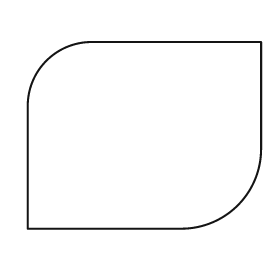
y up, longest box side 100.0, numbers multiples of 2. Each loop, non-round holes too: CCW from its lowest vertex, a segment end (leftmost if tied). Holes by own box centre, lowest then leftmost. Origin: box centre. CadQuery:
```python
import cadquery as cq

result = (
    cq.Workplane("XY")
    .moveTo(-50.0, -40.0)
    .lineTo(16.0, -40.0)
    .threePointArc((40.0, -30.0), (50.0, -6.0))
    .lineTo(50.0, 40.0)
    .lineTo(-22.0, 40.0)
    .threePointArc((-42.0, 32.0), (-50.0, 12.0))
    .close()
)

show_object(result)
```